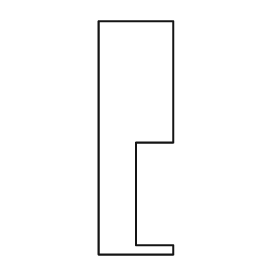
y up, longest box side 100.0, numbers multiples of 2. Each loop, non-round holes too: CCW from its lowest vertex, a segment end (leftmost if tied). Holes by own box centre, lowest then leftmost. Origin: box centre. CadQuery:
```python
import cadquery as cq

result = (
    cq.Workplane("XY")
    .moveTo(-16.0, -50.0)
    .lineTo(16.0, -50.0)
    .lineTo(16.0, -46.0)
    .lineTo(0.0, -46.0)
    .lineTo(0.0, -2.0)
    .lineTo(16.0, -2.0)
    .lineTo(16.0, 50.0)
    .lineTo(-16.0, 50.0)
    .close()
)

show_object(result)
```